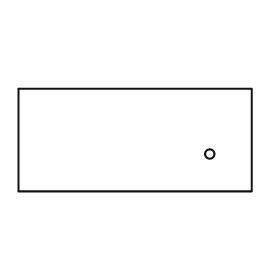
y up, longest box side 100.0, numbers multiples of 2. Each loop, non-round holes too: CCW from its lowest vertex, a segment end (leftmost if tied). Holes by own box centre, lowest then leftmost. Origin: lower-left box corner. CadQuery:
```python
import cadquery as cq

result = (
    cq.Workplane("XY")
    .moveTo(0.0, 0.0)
    .lineTo(100.0, 0.0)
    .lineTo(100.0, 44.0)
    .lineTo(0.0, 44.0)
    .close()
    .moveTo(82.0, 16.0)
    .circle(2.0)
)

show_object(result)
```